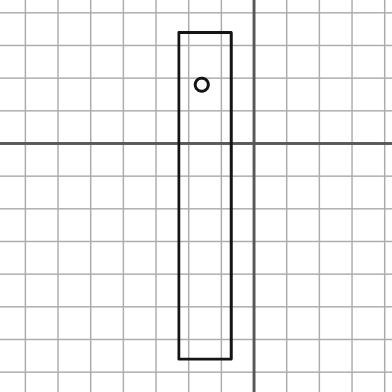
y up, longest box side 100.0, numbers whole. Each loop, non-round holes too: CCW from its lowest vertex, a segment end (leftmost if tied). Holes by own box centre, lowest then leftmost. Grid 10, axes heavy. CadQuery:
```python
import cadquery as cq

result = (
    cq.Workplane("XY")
    .moveTo(-23.0, -66.0)
    .lineTo(-7.0, -66.0)
    .lineTo(-7.0, 34.0)
    .lineTo(-23.0, 34.0)
    .close()
    .moveTo(-16.0, 18.0)
    .circle(2.0)
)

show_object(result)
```